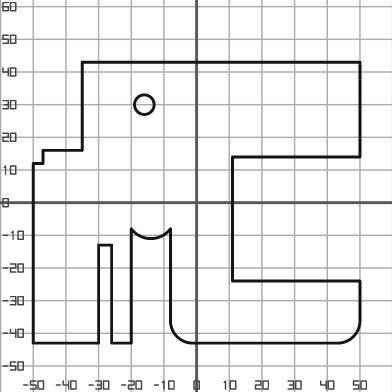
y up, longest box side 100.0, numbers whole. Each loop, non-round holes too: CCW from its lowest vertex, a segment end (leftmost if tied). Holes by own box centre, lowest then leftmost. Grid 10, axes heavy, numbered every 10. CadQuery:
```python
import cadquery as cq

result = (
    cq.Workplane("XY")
    .moveTo(-50.0, -43.0)
    .lineTo(-30.0, -43.0)
    .lineTo(-30.0, -13.0)
    .lineTo(-26.0, -13.0)
    .lineTo(-26.0, -43.0)
    .lineTo(-20.0, -43.0)
    .lineTo(-20.0, -8.0)
    .threePointArc((-14.0, -11.0), (-8.0, -8.0))
    .lineTo(-8.0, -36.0)
    .threePointArc((-6.0, -41.0), (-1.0, -43.0))
    .lineTo(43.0, -43.0)
    .threePointArc((48.0, -41.0), (50.0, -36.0))
    .lineTo(50.0, -24.0)
    .lineTo(11.0, -24.0)
    .lineTo(11.0, 14.0)
    .lineTo(50.0, 14.0)
    .lineTo(50.0, 43.0)
    .lineTo(-35.0, 43.0)
    .lineTo(-35.0, 16.0)
    .lineTo(-47.0, 16.0)
    .lineTo(-47.0, 12.0)
    .lineTo(-50.0, 12.0)
    .close()
    .moveTo(-16.0, 30.0)
    .circle(3.0)
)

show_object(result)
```